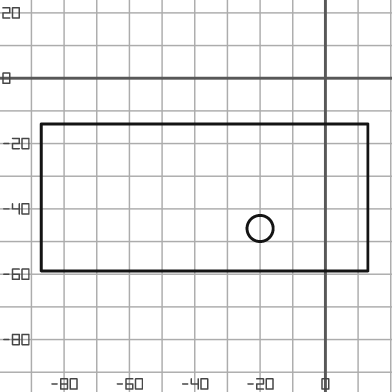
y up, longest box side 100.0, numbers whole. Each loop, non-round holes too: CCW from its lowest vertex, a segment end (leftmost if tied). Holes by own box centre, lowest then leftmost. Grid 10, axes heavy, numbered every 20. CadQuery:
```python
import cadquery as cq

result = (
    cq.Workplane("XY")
    .moveTo(-87.0, -59.0)
    .lineTo(13.0, -59.0)
    .lineTo(13.0, -14.0)
    .lineTo(-87.0, -14.0)
    .close()
    .moveTo(-20.0, -46.0)
    .circle(4.0)
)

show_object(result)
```